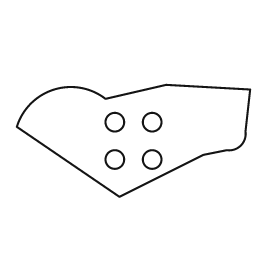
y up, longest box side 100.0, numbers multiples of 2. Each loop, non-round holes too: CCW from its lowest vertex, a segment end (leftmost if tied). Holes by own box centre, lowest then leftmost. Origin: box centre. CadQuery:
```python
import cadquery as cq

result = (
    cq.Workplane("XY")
    .moveTo(-6.0, -24.0)
    .lineTo(30.0, -6.0)
    .lineTo(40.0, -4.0)
    .threePointArc((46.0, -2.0), (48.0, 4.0))
    .lineTo(50.0, 22.0)
    .lineTo(14.0, 24.0)
    .lineTo(-12.0, 18.0)
    .threePointArc((-34.0, 22.0), (-50.0, 6.0))
    .close()
    .moveTo(-8.0, -8.0)
    .circle(4.0)
    .moveTo(8.0, -8.0)
    .circle(4.0)
    .moveTo(-8.0, 8.0)
    .circle(4.0)
    .moveTo(8.0, 8.0)
    .circle(4.0)
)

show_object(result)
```